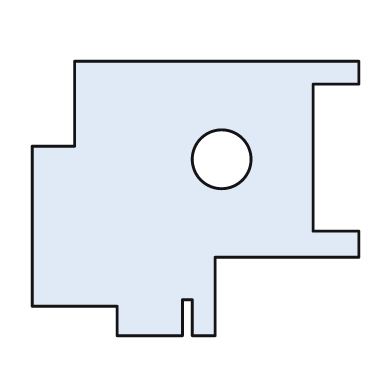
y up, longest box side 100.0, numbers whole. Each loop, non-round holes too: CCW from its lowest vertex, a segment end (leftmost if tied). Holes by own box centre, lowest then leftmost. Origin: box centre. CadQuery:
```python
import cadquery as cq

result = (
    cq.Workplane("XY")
    .moveTo(-24.0, -42.0)
    .lineTo(-4.0, -42.0)
    .lineTo(-4.0, -31.0)
    .lineTo(-1.0, -31.0)
    .lineTo(-1.0, -42.0)
    .lineTo(6.0, -42.0)
    .lineTo(6.0, -18.0)
    .lineTo(50.0, -18.0)
    .lineTo(50.0, -10.0)
    .lineTo(36.0, -10.0)
    .lineTo(36.0, 35.0)
    .lineTo(50.0, 35.0)
    .lineTo(50.0, 42.0)
    .lineTo(-37.0, 42.0)
    .lineTo(-37.0, 16.0)
    .lineTo(-50.0, 16.0)
    .lineTo(-50.0, -33.0)
    .lineTo(-24.0, -33.0)
    .close()
    .moveTo(8.0, 12.0)
    .circle(9.0)
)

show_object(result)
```